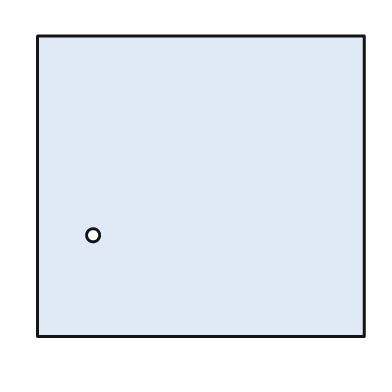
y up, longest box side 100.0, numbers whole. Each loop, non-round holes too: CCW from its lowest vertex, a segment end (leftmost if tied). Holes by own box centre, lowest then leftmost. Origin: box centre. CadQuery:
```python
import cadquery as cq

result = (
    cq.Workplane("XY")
    .moveTo(-50.0, -46.0)
    .lineTo(50.0, -46.0)
    .lineTo(50.0, 46.0)
    .lineTo(-50.0, 46.0)
    .close()
    .moveTo(-33.0, -15.0)
    .circle(2.0)
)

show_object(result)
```